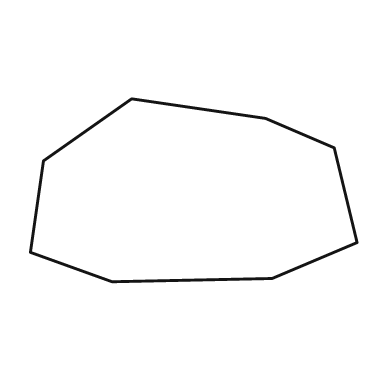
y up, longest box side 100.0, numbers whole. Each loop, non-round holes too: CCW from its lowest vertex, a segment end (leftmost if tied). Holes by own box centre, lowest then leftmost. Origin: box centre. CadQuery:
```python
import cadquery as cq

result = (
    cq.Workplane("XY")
    .moveTo(-25.0, -28.0)
    .lineTo(24.0, -27.0)
    .lineTo(50.0, -16.0)
    .lineTo(43.0, 13.0)
    .lineTo(22.0, 22.0)
    .lineTo(-19.0, 28.0)
    .lineTo(-46.0, 9.0)
    .lineTo(-50.0, -19.0)
    .close()
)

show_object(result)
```